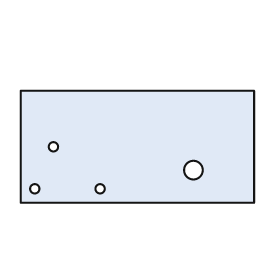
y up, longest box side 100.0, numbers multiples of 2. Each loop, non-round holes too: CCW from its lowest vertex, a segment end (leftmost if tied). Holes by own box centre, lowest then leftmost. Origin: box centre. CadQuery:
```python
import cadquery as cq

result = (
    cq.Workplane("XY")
    .moveTo(-50.0, -24.0)
    .lineTo(50.0, -24.0)
    .lineTo(50.0, 24.0)
    .lineTo(-50.0, 24.0)
    .close()
    .moveTo(-44.0, -18.0)
    .circle(2.0)
    .moveTo(-16.0, -18.0)
    .circle(2.0)
    .moveTo(24.0, -10.0)
    .circle(4.0)
    .moveTo(-36.0, 0.0)
    .circle(2.0)
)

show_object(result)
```